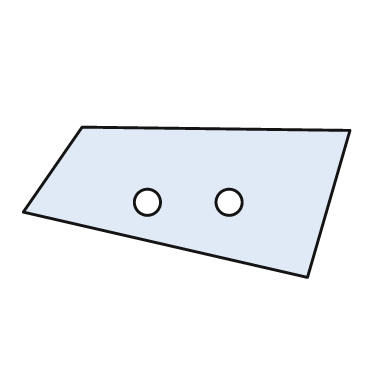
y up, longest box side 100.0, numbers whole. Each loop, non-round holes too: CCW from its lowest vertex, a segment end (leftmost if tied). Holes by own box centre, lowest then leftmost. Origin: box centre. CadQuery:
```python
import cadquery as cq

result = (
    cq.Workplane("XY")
    .moveTo(37.0, -23.0)
    .lineTo(50.0, 22.0)
    .lineTo(-32.0, 23.0)
    .lineTo(-50.0, -3.0)
    .close()
    .moveTo(-12.0, 0.0)
    .circle(4.0)
    .moveTo(13.0, 0.0)
    .circle(4.0)
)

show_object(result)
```